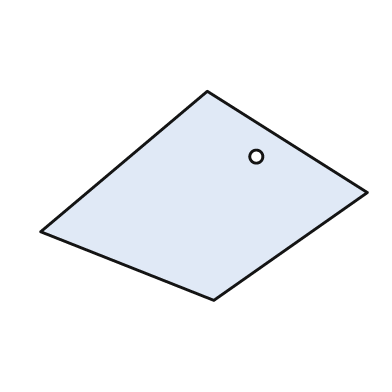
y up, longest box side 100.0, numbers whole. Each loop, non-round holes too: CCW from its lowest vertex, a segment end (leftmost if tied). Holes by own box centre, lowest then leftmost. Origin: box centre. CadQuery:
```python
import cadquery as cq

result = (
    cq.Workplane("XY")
    .moveTo(3.0, -32.0)
    .lineTo(50.0, 1.0)
    .lineTo(1.0, 32.0)
    .lineTo(-50.0, -11.0)
    .close()
    .moveTo(16.0, 12.0)
    .circle(2.0)
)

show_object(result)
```